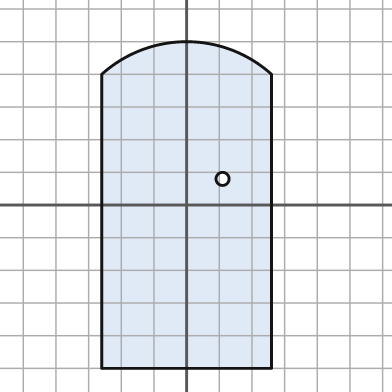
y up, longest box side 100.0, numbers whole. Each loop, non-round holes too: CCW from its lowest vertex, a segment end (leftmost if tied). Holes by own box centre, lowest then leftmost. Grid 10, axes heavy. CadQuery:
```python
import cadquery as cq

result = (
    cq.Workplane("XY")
    .moveTo(-26.0, -50.0)
    .lineTo(26.0, -50.0)
    .lineTo(26.0, 40.0)
    .threePointArc((0.0, 50.0), (-26.0, 40.0))
    .close()
    .moveTo(11.0, 8.0)
    .circle(2.0)
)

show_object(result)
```